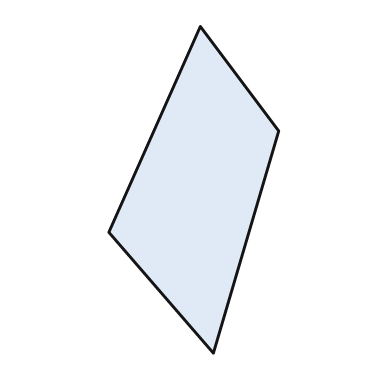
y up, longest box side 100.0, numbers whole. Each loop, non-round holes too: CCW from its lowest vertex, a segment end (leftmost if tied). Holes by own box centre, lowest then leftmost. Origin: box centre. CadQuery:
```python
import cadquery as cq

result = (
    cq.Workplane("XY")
    .moveTo(6.0, -50.0)
    .lineTo(26.0, 18.0)
    .lineTo(2.0, 50.0)
    .lineTo(-26.0, -13.0)
    .close()
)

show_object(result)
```